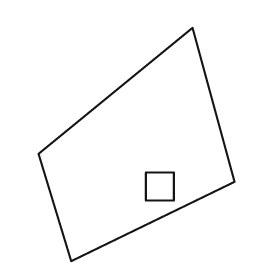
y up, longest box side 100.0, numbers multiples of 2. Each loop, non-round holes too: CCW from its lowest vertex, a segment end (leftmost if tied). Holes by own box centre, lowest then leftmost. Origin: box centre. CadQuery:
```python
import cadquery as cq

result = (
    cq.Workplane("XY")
    .moveTo(-28.0, -50.0)
    .lineTo(42.0, -16.0)
    .lineTo(24.0, 50.0)
    .lineTo(-42.0, -4.0)
    .close()
    .moveTo(4.0, -24.0)
    .lineTo(16.0, -24.0)
    .lineTo(16.0, -12.0)
    .lineTo(4.0, -12.0)
    .close()
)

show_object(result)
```